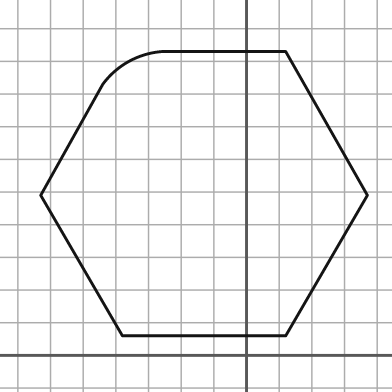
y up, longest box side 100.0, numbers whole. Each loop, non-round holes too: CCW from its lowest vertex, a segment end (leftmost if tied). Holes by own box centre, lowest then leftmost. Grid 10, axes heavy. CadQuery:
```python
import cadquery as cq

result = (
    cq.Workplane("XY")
    .moveTo(-38.0, 6.0)
    .lineTo(12.0, 6.0)
    .lineTo(37.0, 49.0)
    .lineTo(12.0, 93.0)
    .lineTo(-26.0, 93.0)
    .threePointArc((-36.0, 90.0), (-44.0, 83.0))
    .lineTo(-63.0, 49.0)
    .close()
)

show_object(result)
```